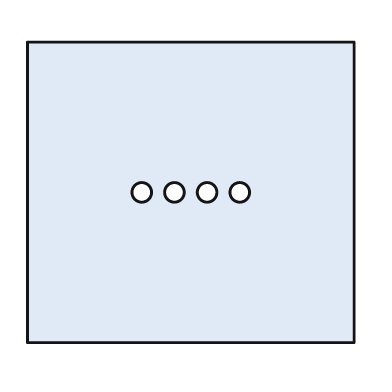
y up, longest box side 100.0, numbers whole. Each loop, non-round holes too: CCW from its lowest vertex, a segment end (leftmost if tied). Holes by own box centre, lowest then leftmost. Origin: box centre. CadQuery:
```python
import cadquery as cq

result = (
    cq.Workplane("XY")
    .moveTo(-50.0, -46.0)
    .lineTo(50.0, -46.0)
    .lineTo(50.0, 46.0)
    .lineTo(-50.0, 46.0)
    .close()
    .moveTo(-15.0, 0.0)
    .circle(3.0)
    .moveTo(-5.0, 0.0)
    .circle(3.0)
    .moveTo(5.0, 0.0)
    .circle(3.0)
    .moveTo(15.0, 0.0)
    .circle(3.0)
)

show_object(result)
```